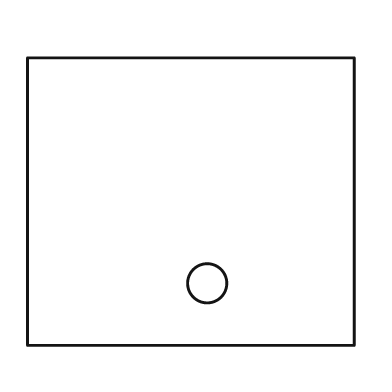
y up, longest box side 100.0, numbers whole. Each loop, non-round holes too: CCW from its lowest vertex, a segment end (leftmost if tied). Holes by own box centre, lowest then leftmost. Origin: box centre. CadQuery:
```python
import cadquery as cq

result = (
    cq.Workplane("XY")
    .moveTo(-50.0, -44.0)
    .lineTo(50.0, -44.0)
    .lineTo(50.0, 44.0)
    .lineTo(-50.0, 44.0)
    .close()
    .moveTo(5.0, -25.0)
    .circle(6.0)
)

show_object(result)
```